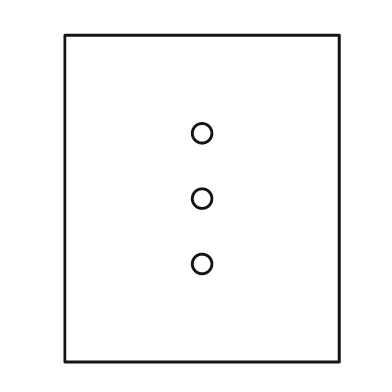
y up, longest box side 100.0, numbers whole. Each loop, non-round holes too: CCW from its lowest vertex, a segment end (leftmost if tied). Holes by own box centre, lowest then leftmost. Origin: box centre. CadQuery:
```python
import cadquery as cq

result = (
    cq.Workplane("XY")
    .moveTo(-42.0, -50.0)
    .lineTo(42.0, -50.0)
    .lineTo(42.0, 50.0)
    .lineTo(-42.0, 50.0)
    .close()
    .moveTo(0.0, -20.0)
    .circle(3.0)
    .moveTo(0.0, 0.0)
    .circle(3.0)
    .moveTo(0.0, 20.0)
    .circle(3.0)
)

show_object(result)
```